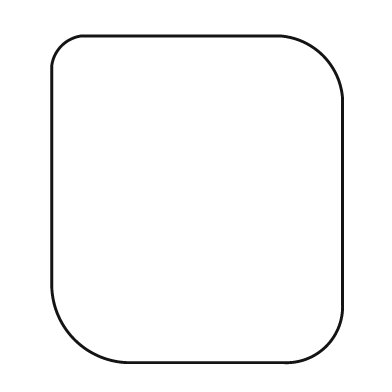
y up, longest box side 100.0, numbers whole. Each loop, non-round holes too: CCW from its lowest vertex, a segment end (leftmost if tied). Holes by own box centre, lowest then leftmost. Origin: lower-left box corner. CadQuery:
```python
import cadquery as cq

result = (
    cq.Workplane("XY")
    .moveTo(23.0, 0.0)
    .lineTo(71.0, 0.0)
    .threePointArc((84.0, 5.0), (89.0, 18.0))
    .lineTo(89.0, 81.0)
    .threePointArc((83.0, 94.0), (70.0, 100.0))
    .lineTo(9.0, 100.0)
    .threePointArc((3.0, 97.0), (0.0, 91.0))
    .lineTo(0.0, 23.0)
    .threePointArc((7.0, 7.0), (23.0, 0.0))
    .close()
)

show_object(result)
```